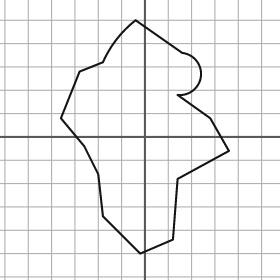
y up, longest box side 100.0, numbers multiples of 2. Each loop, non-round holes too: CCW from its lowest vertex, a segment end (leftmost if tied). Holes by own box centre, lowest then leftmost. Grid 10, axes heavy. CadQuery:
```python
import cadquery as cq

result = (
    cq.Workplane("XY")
    .moveTo(-2.0, -50.0)
    .lineTo(12.0, -44.0)
    .lineTo(14.0, -18.0)
    .lineTo(36.0, -6.0)
    .lineTo(28.0, 8.0)
    .lineTo(14.0, 18.0)
    .threePointArc((24.0, 26.0), (16.0, 36.0))
    .lineTo(-4.0, 50.0)
    .threePointArc((-12.0, 42.0), (-18.0, 32.0))
    .lineTo(-28.0, 28.0)
    .lineTo(-36.0, 8.0)
    .lineTo(-26.0, -4.0)
    .lineTo(-20.0, -16.0)
    .lineTo(-18.0, -34.0)
    .close()
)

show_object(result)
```